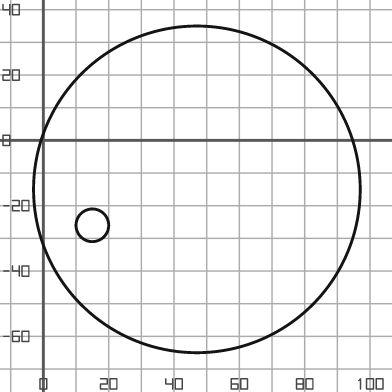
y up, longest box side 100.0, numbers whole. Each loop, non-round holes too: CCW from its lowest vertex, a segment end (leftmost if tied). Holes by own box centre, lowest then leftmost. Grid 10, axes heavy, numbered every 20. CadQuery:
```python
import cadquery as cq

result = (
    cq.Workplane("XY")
    .moveTo(47.0, -15.0)
    .circle(50.0)
    .moveTo(15.0, -26.0)
    .circle(5.0)
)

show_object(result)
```